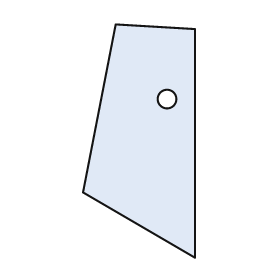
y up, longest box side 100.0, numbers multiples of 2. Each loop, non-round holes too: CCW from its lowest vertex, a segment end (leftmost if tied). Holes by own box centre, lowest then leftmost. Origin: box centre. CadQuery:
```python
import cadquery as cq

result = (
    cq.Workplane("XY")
    .moveTo(24.0, -50.0)
    .lineTo(24.0, 48.0)
    .lineTo(-10.0, 50.0)
    .lineTo(-24.0, -22.0)
    .close()
    .moveTo(12.0, 18.0)
    .circle(4.0)
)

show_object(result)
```